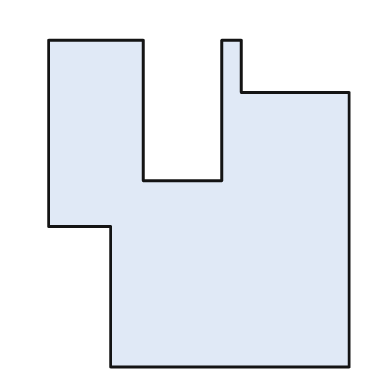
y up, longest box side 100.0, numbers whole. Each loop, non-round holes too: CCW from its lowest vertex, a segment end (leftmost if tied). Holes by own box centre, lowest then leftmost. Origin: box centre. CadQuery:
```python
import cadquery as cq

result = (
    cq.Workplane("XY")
    .moveTo(-27.0, -50.0)
    .lineTo(46.0, -50.0)
    .lineTo(46.0, 34.0)
    .lineTo(13.0, 34.0)
    .lineTo(13.0, 50.0)
    .lineTo(7.0, 50.0)
    .lineTo(7.0, 7.0)
    .lineTo(-17.0, 7.0)
    .lineTo(-17.0, 50.0)
    .lineTo(-46.0, 50.0)
    .lineTo(-46.0, -7.0)
    .lineTo(-27.0, -7.0)
    .close()
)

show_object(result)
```